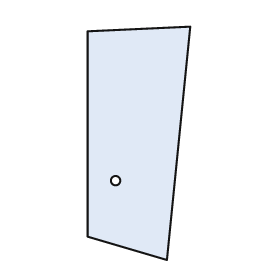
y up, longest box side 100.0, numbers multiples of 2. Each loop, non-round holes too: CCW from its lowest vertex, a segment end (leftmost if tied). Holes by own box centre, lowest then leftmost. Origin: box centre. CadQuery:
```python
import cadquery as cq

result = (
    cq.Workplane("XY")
    .moveTo(12.0, -50.0)
    .lineTo(22.0, 50.0)
    .lineTo(-22.0, 48.0)
    .lineTo(-22.0, -40.0)
    .close()
    .moveTo(-10.0, -16.0)
    .circle(2.0)
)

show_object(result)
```